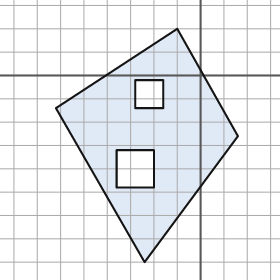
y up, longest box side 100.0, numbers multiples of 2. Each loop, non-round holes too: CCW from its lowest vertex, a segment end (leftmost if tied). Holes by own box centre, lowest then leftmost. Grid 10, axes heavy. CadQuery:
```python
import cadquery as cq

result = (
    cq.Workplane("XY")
    .moveTo(-24.0, -80.0)
    .lineTo(16.0, -26.0)
    .lineTo(-10.0, 20.0)
    .lineTo(-62.0, -14.0)
    .close()
    .moveTo(-36.0, -48.0)
    .lineTo(-20.0, -48.0)
    .lineTo(-20.0, -32.0)
    .lineTo(-36.0, -32.0)
    .close()
    .moveTo(-28.0, -14.0)
    .lineTo(-16.0, -14.0)
    .lineTo(-16.0, -2.0)
    .lineTo(-28.0, -2.0)
    .close()
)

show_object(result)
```